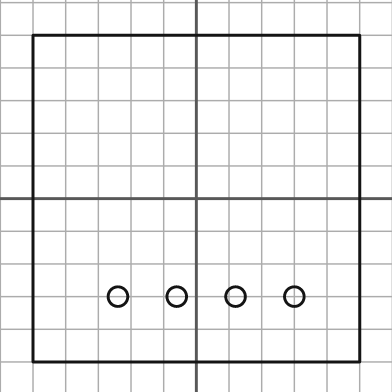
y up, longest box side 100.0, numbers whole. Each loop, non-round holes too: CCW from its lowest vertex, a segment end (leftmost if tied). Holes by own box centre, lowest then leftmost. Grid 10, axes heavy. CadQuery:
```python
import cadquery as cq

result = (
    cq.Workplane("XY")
    .moveTo(-50.0, -50.0)
    .lineTo(50.0, -50.0)
    .lineTo(50.0, 50.0)
    .lineTo(-50.0, 50.0)
    .close()
    .moveTo(-24.0, -30.0)
    .circle(3.0)
    .moveTo(-6.0, -30.0)
    .circle(3.0)
    .moveTo(12.0, -30.0)
    .circle(3.0)
    .moveTo(30.0, -30.0)
    .circle(3.0)
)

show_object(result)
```